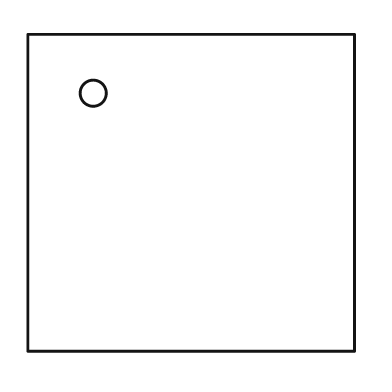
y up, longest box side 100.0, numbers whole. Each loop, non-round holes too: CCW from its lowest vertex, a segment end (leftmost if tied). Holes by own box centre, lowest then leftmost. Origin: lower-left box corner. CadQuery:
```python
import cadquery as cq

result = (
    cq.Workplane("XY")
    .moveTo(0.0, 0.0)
    .lineTo(100.0, 0.0)
    .lineTo(100.0, 97.0)
    .lineTo(0.0, 97.0)
    .close()
    .moveTo(20.0, 79.0)
    .circle(4.0)
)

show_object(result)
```